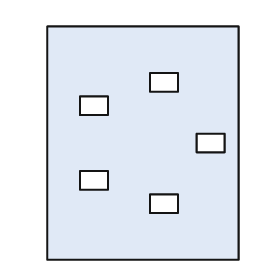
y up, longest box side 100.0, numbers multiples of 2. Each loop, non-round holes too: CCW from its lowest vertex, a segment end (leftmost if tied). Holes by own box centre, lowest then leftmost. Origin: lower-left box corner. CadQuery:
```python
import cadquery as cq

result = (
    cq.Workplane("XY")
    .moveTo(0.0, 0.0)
    .lineTo(82.0, 0.0)
    .lineTo(82.0, 100.0)
    .lineTo(0.0, 100.0)
    .close()
    .moveTo(44.0, 20.0)
    .lineTo(56.0, 20.0)
    .lineTo(56.0, 28.0)
    .lineTo(44.0, 28.0)
    .close()
    .moveTo(14.0, 30.0)
    .lineTo(26.0, 30.0)
    .lineTo(26.0, 38.0)
    .lineTo(14.0, 38.0)
    .close()
    .moveTo(64.0, 46.0)
    .lineTo(76.0, 46.0)
    .lineTo(76.0, 54.0)
    .lineTo(64.0, 54.0)
    .close()
    .moveTo(14.0, 62.0)
    .lineTo(26.0, 62.0)
    .lineTo(26.0, 70.0)
    .lineTo(14.0, 70.0)
    .close()
    .moveTo(44.0, 72.0)
    .lineTo(56.0, 72.0)
    .lineTo(56.0, 80.0)
    .lineTo(44.0, 80.0)
    .close()
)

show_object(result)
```